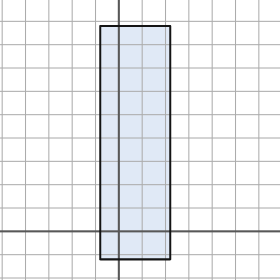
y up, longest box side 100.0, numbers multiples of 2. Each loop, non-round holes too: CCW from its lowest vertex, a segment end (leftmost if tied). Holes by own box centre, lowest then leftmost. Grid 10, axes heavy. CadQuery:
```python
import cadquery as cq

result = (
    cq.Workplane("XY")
    .moveTo(-8.0, -12.0)
    .lineTo(22.0, -12.0)
    .lineTo(22.0, 88.0)
    .lineTo(-8.0, 88.0)
    .close()
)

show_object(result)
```